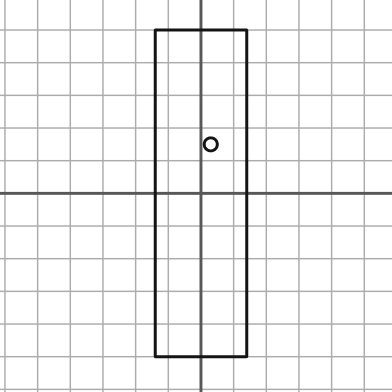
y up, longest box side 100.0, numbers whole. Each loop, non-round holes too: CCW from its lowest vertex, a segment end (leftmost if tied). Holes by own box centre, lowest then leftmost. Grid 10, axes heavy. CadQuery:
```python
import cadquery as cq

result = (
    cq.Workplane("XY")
    .moveTo(-14.0, -50.0)
    .lineTo(14.0, -50.0)
    .lineTo(14.0, 50.0)
    .lineTo(-14.0, 50.0)
    .close()
    .moveTo(3.0, 15.0)
    .circle(2.0)
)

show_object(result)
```